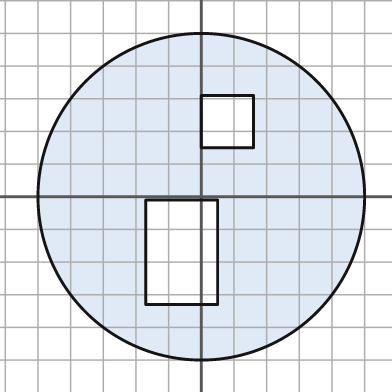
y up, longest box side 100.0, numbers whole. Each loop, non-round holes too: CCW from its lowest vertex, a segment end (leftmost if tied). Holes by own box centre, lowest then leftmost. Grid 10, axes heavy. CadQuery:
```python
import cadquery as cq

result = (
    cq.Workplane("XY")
    .moveTo(0.0, 0.0)
    .circle(50.0)
    .moveTo(-17.0, -33.0)
    .lineTo(5.0, -33.0)
    .lineTo(5.0, -1.0)
    .lineTo(-17.0, -1.0)
    .close()
    .moveTo(0.0, 15.0)
    .lineTo(16.0, 15.0)
    .lineTo(16.0, 31.0)
    .lineTo(0.0, 31.0)
    .close()
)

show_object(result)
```